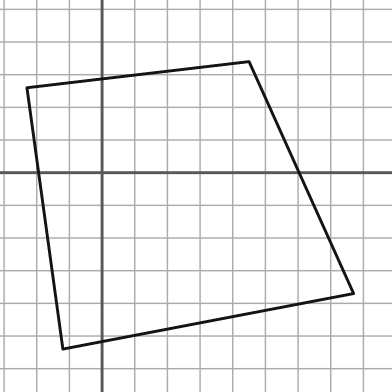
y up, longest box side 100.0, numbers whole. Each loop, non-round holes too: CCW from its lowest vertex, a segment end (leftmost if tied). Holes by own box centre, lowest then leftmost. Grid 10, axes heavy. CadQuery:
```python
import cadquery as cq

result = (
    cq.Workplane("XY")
    .moveTo(-12.0, -54.0)
    .lineTo(77.0, -37.0)
    .lineTo(45.0, 34.0)
    .lineTo(-23.0, 26.0)
    .close()
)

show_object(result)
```